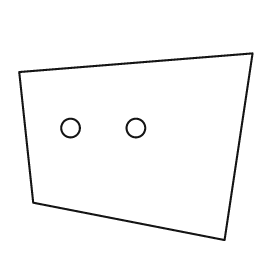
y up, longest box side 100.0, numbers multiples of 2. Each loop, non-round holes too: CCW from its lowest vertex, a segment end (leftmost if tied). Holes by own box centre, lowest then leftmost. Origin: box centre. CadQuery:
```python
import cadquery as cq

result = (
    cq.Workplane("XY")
    .moveTo(38.0, -40.0)
    .lineTo(50.0, 40.0)
    .lineTo(-50.0, 32.0)
    .lineTo(-44.0, -24.0)
    .close()
    .moveTo(-28.0, 8.0)
    .circle(4.0)
    .moveTo(0.0, 8.0)
    .circle(4.0)
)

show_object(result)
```